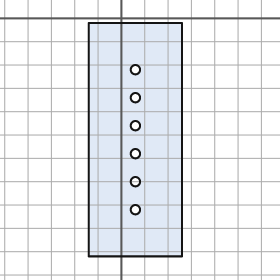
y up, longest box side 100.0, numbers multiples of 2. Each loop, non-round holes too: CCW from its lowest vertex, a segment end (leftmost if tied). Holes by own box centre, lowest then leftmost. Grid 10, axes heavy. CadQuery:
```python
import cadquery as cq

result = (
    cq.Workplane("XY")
    .moveTo(-14.0, -102.0)
    .lineTo(26.0, -102.0)
    .lineTo(26.0, -2.0)
    .lineTo(-14.0, -2.0)
    .close()
    .moveTo(6.0, -82.0)
    .circle(2.0)
    .moveTo(6.0, -70.0)
    .circle(2.0)
    .moveTo(6.0, -58.0)
    .circle(2.0)
    .moveTo(6.0, -46.0)
    .circle(2.0)
    .moveTo(6.0, -34.0)
    .circle(2.0)
    .moveTo(6.0, -22.0)
    .circle(2.0)
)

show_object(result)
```